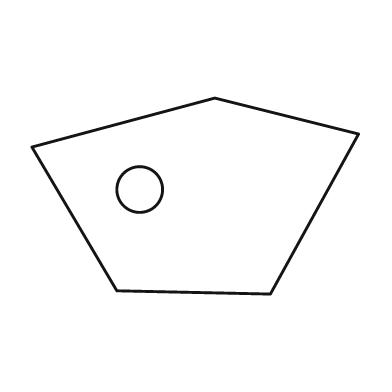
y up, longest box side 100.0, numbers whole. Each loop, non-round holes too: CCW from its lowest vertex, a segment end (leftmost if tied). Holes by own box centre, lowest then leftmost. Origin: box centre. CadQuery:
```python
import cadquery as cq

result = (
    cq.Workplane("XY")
    .moveTo(23.0, -30.0)
    .lineTo(50.0, 19.0)
    .lineTo(6.0, 30.0)
    .lineTo(-50.0, 15.0)
    .lineTo(-24.0, -29.0)
    .close()
    .moveTo(-17.0, 2.0)
    .circle(7.0)
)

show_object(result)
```